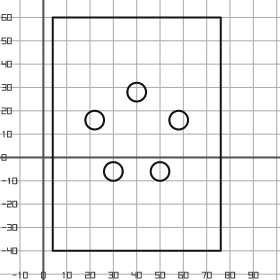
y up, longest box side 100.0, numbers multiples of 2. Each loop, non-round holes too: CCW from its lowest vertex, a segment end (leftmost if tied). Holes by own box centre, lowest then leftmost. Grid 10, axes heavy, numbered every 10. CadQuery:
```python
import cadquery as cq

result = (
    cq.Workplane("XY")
    .moveTo(4.0, -40.0)
    .lineTo(76.0, -40.0)
    .lineTo(76.0, 60.0)
    .lineTo(4.0, 60.0)
    .close()
    .moveTo(30.0, -6.0)
    .circle(4.0)
    .moveTo(50.0, -6.0)
    .circle(4.0)
    .moveTo(22.0, 16.0)
    .circle(4.0)
    .moveTo(58.0, 16.0)
    .circle(4.0)
    .moveTo(40.0, 28.0)
    .circle(4.0)
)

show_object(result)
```